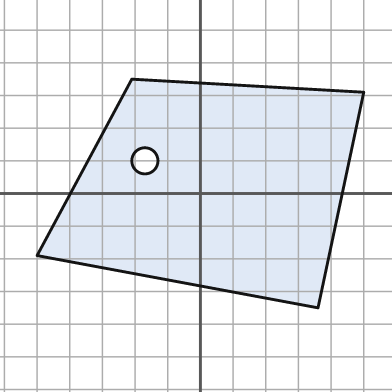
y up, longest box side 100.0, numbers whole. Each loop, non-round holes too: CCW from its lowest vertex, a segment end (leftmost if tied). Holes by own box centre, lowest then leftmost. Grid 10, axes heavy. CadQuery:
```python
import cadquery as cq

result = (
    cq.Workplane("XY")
    .moveTo(36.0, -35.0)
    .lineTo(50.0, 31.0)
    .lineTo(-21.0, 35.0)
    .lineTo(-50.0, -19.0)
    .close()
    .moveTo(-17.0, 10.0)
    .circle(4.0)
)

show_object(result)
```